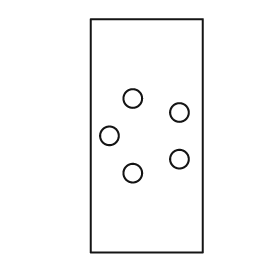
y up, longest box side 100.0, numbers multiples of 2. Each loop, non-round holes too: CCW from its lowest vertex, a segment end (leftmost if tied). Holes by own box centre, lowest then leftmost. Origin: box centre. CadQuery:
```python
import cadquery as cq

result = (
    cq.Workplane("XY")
    .moveTo(-24.0, -50.0)
    .lineTo(24.0, -50.0)
    .lineTo(24.0, 50.0)
    .lineTo(-24.0, 50.0)
    .close()
    .moveTo(-6.0, -16.0)
    .circle(4.0)
    .moveTo(14.0, -10.0)
    .circle(4.0)
    .moveTo(-16.0, 0.0)
    .circle(4.0)
    .moveTo(14.0, 10.0)
    .circle(4.0)
    .moveTo(-6.0, 16.0)
    .circle(4.0)
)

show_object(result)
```